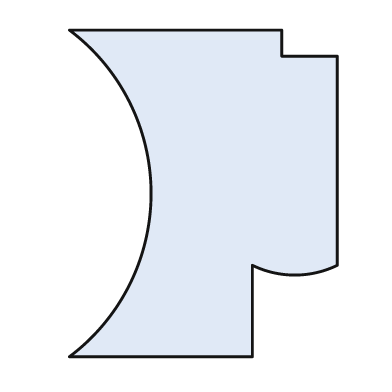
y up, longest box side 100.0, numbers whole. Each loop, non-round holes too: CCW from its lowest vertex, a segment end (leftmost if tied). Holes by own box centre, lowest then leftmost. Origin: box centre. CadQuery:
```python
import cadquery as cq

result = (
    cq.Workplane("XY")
    .moveTo(-41.0, -50.0)
    .lineTo(15.0, -50.0)
    .lineTo(15.0, -22.0)
    .threePointArc((28.0, -25.0), (41.0, -22.0))
    .lineTo(41.0, 42.0)
    .lineTo(24.0, 42.0)
    .lineTo(24.0, 50.0)
    .lineTo(-41.0, 50.0)
    .threePointArc((-16.0, 0.0), (-41.0, -50.0))
    .close()
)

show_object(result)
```